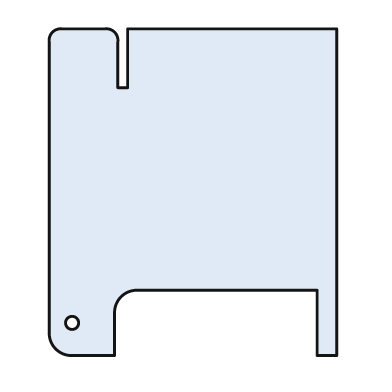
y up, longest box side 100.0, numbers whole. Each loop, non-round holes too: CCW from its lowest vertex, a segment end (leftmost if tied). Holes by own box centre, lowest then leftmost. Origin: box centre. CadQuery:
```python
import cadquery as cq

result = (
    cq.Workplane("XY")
    .moveTo(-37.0, -50.0)
    .lineTo(-24.0, -50.0)
    .lineTo(-24.0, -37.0)
    .threePointArc((-22.0, -32.0), (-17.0, -30.0))
    .lineTo(38.0, -30.0)
    .lineTo(38.0, -50.0)
    .lineTo(44.0, -50.0)
    .lineTo(44.0, 50.0)
    .lineTo(-20.0, 50.0)
    .lineTo(-20.0, 32.0)
    .lineTo(-23.0, 32.0)
    .lineTo(-23.0, 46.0)
    .threePointArc((-24.0, 49.0), (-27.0, 50.0))
    .lineTo(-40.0, 50.0)
    .threePointArc((-43.0, 49.0), (-44.0, 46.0))
    .lineTo(-44.0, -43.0)
    .threePointArc((-42.0, -48.0), (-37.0, -50.0))
    .close()
    .moveTo(-37.0, -40.0)
    .circle(2.0)
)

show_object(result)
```